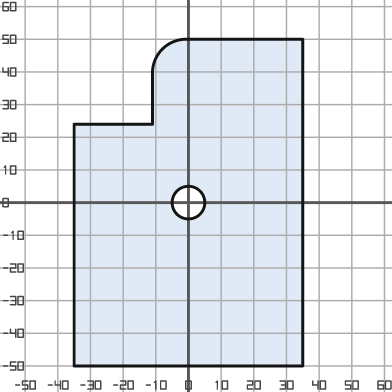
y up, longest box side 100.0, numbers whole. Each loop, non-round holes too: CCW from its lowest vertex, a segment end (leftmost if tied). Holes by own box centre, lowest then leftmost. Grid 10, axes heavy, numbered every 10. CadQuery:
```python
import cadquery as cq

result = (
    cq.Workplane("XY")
    .moveTo(-35.0, -50.0)
    .lineTo(35.0, -50.0)
    .lineTo(35.0, 50.0)
    .lineTo(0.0, 50.0)
    .threePointArc((-8.0, 47.0), (-11.0, 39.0))
    .lineTo(-11.0, 24.0)
    .lineTo(-35.0, 24.0)
    .close()
    .moveTo(0.0, 0.0)
    .circle(5.0)
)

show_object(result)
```